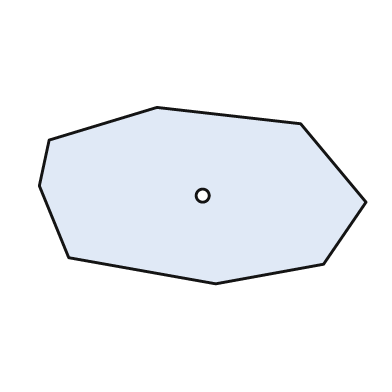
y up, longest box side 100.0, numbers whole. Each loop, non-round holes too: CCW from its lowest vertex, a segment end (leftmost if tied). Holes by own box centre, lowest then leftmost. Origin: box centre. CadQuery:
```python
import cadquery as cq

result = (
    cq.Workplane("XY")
    .moveTo(4.0, -27.0)
    .lineTo(37.0, -21.0)
    .lineTo(50.0, -2.0)
    .lineTo(30.0, 22.0)
    .lineTo(-14.0, 27.0)
    .lineTo(-47.0, 17.0)
    .lineTo(-50.0, 3.0)
    .lineTo(-41.0, -19.0)
    .close()
    .moveTo(0.0, 0.0)
    .circle(2.0)
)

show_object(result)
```